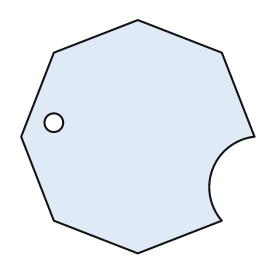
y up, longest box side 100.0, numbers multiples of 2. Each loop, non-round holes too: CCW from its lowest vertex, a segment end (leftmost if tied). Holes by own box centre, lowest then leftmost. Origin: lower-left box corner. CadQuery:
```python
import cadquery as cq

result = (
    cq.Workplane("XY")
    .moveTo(50.0, 0.0)
    .lineTo(86.0, 14.0)
    .threePointArc((82.0, 36.0), (100.0, 50.0))
    .lineTo(86.0, 86.0)
    .lineTo(50.0, 100.0)
    .lineTo(14.0, 86.0)
    .lineTo(0.0, 50.0)
    .lineTo(14.0, 14.0)
    .close()
    .moveTo(14.0, 56.0)
    .circle(4.0)
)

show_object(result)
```